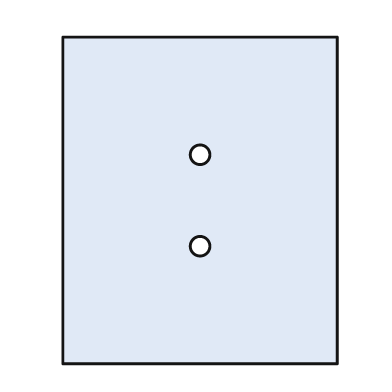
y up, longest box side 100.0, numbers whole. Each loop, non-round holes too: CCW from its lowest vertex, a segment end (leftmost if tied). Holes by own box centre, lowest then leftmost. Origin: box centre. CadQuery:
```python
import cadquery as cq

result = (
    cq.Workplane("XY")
    .moveTo(-42.0, -50.0)
    .lineTo(42.0, -50.0)
    .lineTo(42.0, 50.0)
    .lineTo(-42.0, 50.0)
    .close()
    .moveTo(0.0, -14.0)
    .circle(3.0)
    .moveTo(0.0, 14.0)
    .circle(3.0)
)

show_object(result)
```